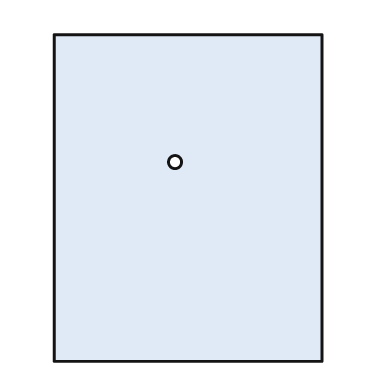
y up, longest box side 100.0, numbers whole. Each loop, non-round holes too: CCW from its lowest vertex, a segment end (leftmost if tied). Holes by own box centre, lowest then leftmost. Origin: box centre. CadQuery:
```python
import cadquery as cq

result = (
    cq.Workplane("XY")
    .moveTo(-41.0, -50.0)
    .lineTo(41.0, -50.0)
    .lineTo(41.0, 50.0)
    .lineTo(-41.0, 50.0)
    .close()
    .moveTo(-4.0, 11.0)
    .circle(2.0)
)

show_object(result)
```